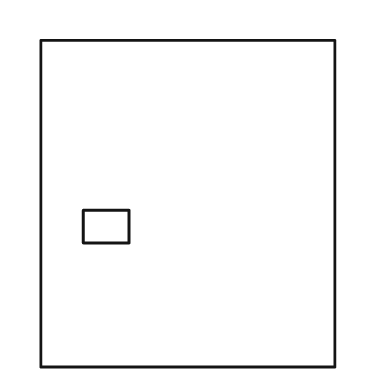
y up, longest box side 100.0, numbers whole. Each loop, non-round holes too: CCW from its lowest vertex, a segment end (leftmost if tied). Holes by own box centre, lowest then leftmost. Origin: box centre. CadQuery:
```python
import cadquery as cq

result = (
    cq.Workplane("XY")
    .moveTo(-45.0, -50.0)
    .lineTo(45.0, -50.0)
    .lineTo(45.0, 50.0)
    .lineTo(-45.0, 50.0)
    .close()
    .moveTo(-32.0, -12.0)
    .lineTo(-18.0, -12.0)
    .lineTo(-18.0, -2.0)
    .lineTo(-32.0, -2.0)
    .close()
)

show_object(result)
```